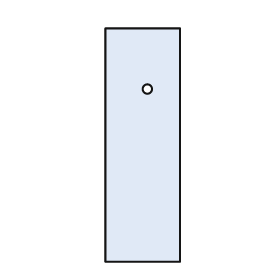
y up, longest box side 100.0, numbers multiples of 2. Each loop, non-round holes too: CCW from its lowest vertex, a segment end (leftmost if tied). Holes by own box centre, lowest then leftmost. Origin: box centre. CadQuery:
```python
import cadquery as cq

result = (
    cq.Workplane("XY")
    .moveTo(-16.0, -50.0)
    .lineTo(16.0, -50.0)
    .lineTo(16.0, 50.0)
    .lineTo(-16.0, 50.0)
    .close()
    .moveTo(2.0, 24.0)
    .circle(2.0)
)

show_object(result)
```